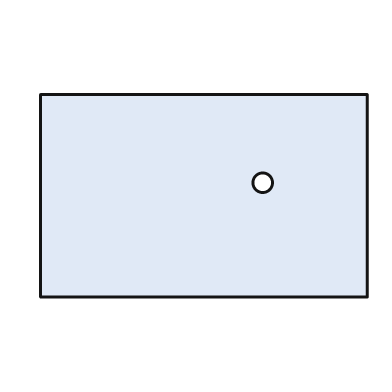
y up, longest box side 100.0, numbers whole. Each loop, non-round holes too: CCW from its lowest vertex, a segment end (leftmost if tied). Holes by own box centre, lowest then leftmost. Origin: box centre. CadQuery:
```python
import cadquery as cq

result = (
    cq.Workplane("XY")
    .moveTo(-50.0, -31.0)
    .lineTo(50.0, -31.0)
    .lineTo(50.0, 31.0)
    .lineTo(-50.0, 31.0)
    .close()
    .moveTo(18.0, 4.0)
    .circle(3.0)
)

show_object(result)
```